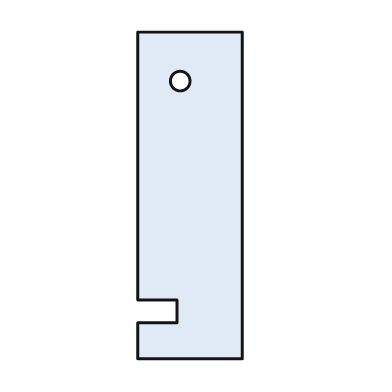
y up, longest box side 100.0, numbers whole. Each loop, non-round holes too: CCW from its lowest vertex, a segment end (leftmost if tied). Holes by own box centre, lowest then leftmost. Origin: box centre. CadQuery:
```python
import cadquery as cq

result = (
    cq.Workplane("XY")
    .moveTo(-16.0, -50.0)
    .lineTo(16.0, -50.0)
    .lineTo(16.0, 50.0)
    .lineTo(-16.0, 50.0)
    .lineTo(-16.0, -32.0)
    .lineTo(-4.0, -32.0)
    .lineTo(-4.0, -39.0)
    .lineTo(-16.0, -39.0)
    .close()
    .moveTo(-3.0, 35.0)
    .circle(3.0)
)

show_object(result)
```